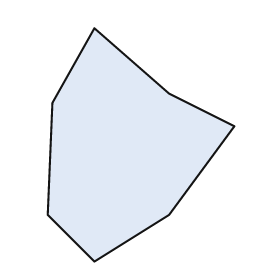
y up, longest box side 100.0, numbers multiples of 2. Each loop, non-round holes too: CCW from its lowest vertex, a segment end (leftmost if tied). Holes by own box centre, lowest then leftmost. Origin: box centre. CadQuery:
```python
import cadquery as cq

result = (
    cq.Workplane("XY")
    .moveTo(-20.0, -50.0)
    .lineTo(12.0, -30.0)
    .lineTo(40.0, 8.0)
    .lineTo(12.0, 22.0)
    .lineTo(-20.0, 50.0)
    .lineTo(-38.0, 18.0)
    .lineTo(-40.0, -30.0)
    .close()
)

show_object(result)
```